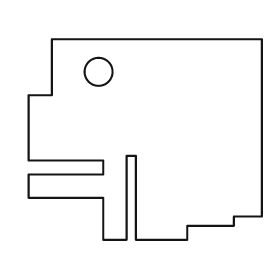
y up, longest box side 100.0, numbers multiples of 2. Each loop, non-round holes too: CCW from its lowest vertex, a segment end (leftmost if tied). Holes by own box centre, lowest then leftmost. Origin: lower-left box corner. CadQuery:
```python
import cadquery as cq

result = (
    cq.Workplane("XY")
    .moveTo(32.0, 0.0)
    .lineTo(42.0, 0.0)
    .lineTo(42.0, 36.0)
    .lineTo(46.0, 36.0)
    .lineTo(46.0, 0.0)
    .lineTo(68.0, 0.0)
    .lineTo(68.0, 6.0)
    .lineTo(88.0, 6.0)
    .lineTo(88.0, 10.0)
    .lineTo(100.0, 10.0)
    .lineTo(100.0, 86.0)
    .lineTo(10.0, 86.0)
    .lineTo(10.0, 62.0)
    .lineTo(0.0, 62.0)
    .lineTo(0.0, 34.0)
    .lineTo(32.0, 34.0)
    .lineTo(32.0, 28.0)
    .lineTo(0.0, 28.0)
    .lineTo(0.0, 18.0)
    .lineTo(32.0, 18.0)
    .close()
    .moveTo(30.0, 72.0)
    .circle(6.0)
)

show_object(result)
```